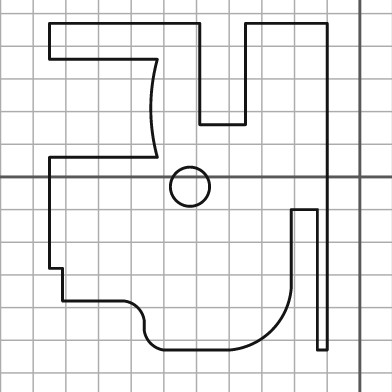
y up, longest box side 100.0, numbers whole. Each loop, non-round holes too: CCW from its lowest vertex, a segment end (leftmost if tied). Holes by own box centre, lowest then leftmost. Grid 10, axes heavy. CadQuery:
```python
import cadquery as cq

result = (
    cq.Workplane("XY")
    .moveTo(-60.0, -53.0)
    .lineTo(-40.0, -53.0)
    .threePointArc((-27.0, -47.0), (-21.0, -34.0))
    .lineTo(-21.0, -10.0)
    .lineTo(-13.0, -10.0)
    .lineTo(-13.0, -53.0)
    .lineTo(-10.0, -53.0)
    .lineTo(-10.0, 47.0)
    .lineTo(-35.0, 47.0)
    .lineTo(-35.0, 16.0)
    .lineTo(-49.0, 16.0)
    .lineTo(-49.0, 47.0)
    .lineTo(-95.0, 47.0)
    .lineTo(-95.0, 36.0)
    .lineTo(-62.0, 36.0)
    .threePointArc((-64.0, 21.0), (-62.0, 6.0))
    .lineTo(-95.0, 6.0)
    .lineTo(-95.0, -28.0)
    .lineTo(-91.0, -28.0)
    .lineTo(-91.0, -38.0)
    .lineTo(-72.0, -38.0)
    .threePointArc((-68.0, -40.0), (-66.0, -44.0))
    .lineTo(-66.0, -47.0)
    .threePointArc((-64.0, -51.0), (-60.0, -53.0))
    .close()
    .moveTo(-52.0, -3.0)
    .circle(6.0)
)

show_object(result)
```